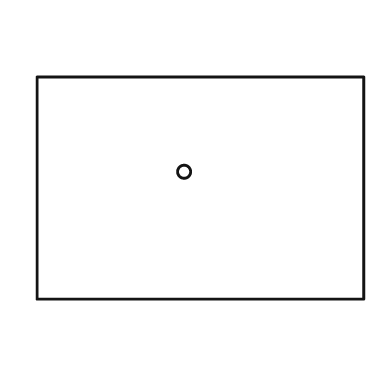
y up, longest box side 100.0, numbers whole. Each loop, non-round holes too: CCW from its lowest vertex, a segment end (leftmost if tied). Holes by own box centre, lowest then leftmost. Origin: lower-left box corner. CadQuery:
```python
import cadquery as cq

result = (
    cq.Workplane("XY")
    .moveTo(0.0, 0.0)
    .lineTo(100.0, 0.0)
    .lineTo(100.0, 68.0)
    .lineTo(0.0, 68.0)
    .close()
    .moveTo(45.0, 39.0)
    .circle(2.0)
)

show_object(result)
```